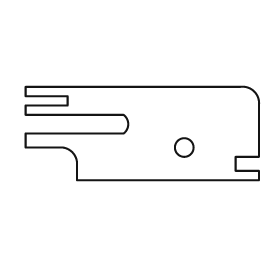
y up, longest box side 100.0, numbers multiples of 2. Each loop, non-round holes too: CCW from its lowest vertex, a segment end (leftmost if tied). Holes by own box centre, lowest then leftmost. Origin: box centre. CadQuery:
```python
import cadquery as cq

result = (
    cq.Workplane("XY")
    .moveTo(-28.0, -20.0)
    .lineTo(50.0, -20.0)
    .lineTo(50.0, -16.0)
    .lineTo(40.0, -16.0)
    .lineTo(40.0, -10.0)
    .lineTo(50.0, -10.0)
    .lineTo(50.0, 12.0)
    .threePointArc((48.0, 18.0), (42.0, 20.0))
    .lineTo(-50.0, 20.0)
    .lineTo(-50.0, 16.0)
    .lineTo(-32.0, 16.0)
    .lineTo(-32.0, 12.0)
    .lineTo(-50.0, 12.0)
    .lineTo(-50.0, 8.0)
    .lineTo(-8.0, 8.0)
    .threePointArc((-6.0, 4.0), (-8.0, 0.0))
    .lineTo(-50.0, 0.0)
    .lineTo(-50.0, -6.0)
    .lineTo(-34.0, -6.0)
    .threePointArc((-30.0, -8.0), (-28.0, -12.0))
    .close()
    .moveTo(18.0, -6.0)
    .circle(4.0)
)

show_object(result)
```